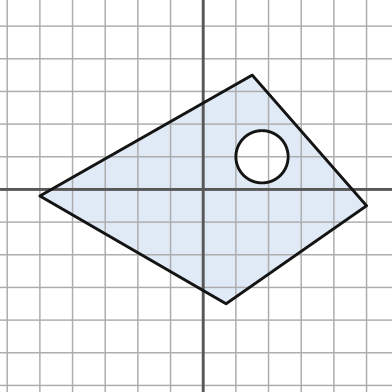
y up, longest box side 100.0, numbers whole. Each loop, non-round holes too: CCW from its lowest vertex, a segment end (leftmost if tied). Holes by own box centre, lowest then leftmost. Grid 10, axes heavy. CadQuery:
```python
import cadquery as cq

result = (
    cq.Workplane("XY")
    .moveTo(7.0, -35.0)
    .lineTo(50.0, -5.0)
    .lineTo(15.0, 35.0)
    .lineTo(-50.0, -2.0)
    .close()
    .moveTo(18.0, 10.0)
    .circle(8.0)
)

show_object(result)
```